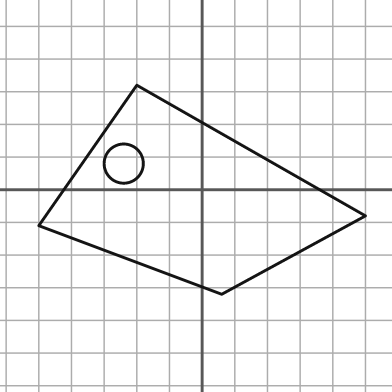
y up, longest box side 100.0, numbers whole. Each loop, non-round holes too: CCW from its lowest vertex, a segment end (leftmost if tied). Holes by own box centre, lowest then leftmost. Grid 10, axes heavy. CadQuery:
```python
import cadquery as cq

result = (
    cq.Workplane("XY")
    .moveTo(6.0, -32.0)
    .lineTo(50.0, -8.0)
    .lineTo(-20.0, 32.0)
    .lineTo(-50.0, -11.0)
    .close()
    .moveTo(-24.0, 8.0)
    .circle(6.0)
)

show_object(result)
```